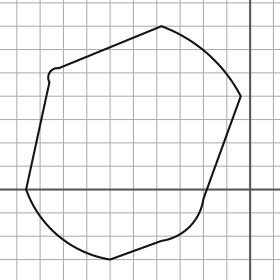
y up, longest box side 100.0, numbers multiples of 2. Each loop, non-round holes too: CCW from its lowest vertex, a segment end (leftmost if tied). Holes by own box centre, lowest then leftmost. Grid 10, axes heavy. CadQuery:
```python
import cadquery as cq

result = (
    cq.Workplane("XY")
    .moveTo(-60.0, -30.0)
    .lineTo(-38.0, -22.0)
    .threePointArc((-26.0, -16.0), (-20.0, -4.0))
    .lineTo(-4.0, 40.0)
    .threePointArc((-18.0, 58.0), (-38.0, 70.0))
    .lineTo(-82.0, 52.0)
    .threePointArc((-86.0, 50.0), (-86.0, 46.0))
    .lineTo(-96.0, 0.0)
    .threePointArc((-82.0, -20.0), (-60.0, -30.0))
    .close()
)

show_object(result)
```